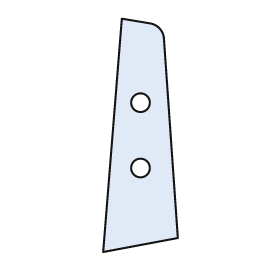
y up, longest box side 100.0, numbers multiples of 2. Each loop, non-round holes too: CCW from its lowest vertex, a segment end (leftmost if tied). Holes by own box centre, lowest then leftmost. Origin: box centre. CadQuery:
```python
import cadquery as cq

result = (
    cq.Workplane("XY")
    .moveTo(-16.0, -50.0)
    .lineTo(16.0, -44.0)
    .lineTo(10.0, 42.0)
    .threePointArc((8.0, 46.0), (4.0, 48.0))
    .lineTo(-8.0, 50.0)
    .close()
    .moveTo(0.0, -14.0)
    .circle(4.0)
    .moveTo(0.0, 14.0)
    .circle(4.0)
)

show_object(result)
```